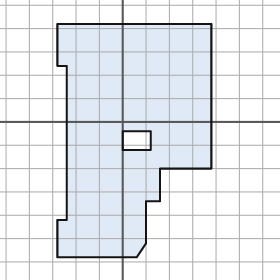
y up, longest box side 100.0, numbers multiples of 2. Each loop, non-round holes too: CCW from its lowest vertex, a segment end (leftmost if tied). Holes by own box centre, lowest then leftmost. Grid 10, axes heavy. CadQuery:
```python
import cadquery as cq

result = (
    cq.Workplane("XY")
    .moveTo(-28.0, -58.0)
    .lineTo(6.0, -58.0)
    .lineTo(10.0, -52.0)
    .lineTo(10.0, -34.0)
    .lineTo(16.0, -34.0)
    .lineTo(16.0, -20.0)
    .lineTo(38.0, -20.0)
    .lineTo(38.0, 42.0)
    .lineTo(-28.0, 42.0)
    .lineTo(-28.0, 24.0)
    .lineTo(-24.0, 24.0)
    .lineTo(-24.0, -42.0)
    .lineTo(-28.0, -42.0)
    .close()
    .moveTo(0.0, -12.0)
    .lineTo(12.0, -12.0)
    .lineTo(12.0, -4.0)
    .lineTo(0.0, -4.0)
    .close()
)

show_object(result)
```